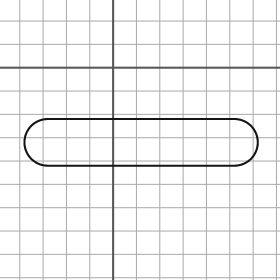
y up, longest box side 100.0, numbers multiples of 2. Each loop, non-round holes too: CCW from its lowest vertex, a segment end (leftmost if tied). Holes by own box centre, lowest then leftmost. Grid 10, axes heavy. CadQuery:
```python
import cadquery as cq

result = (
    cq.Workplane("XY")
    .moveTo(-28.0, -42.0)
    .lineTo(52.0, -42.0)
    .threePointArc((62.0, -32.0), (52.0, -22.0))
    .lineTo(-28.0, -22.0)
    .threePointArc((-38.0, -32.0), (-28.0, -42.0))
    .close()
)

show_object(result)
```